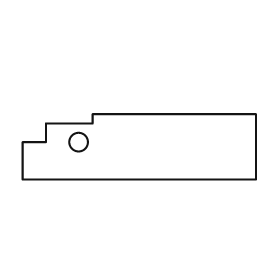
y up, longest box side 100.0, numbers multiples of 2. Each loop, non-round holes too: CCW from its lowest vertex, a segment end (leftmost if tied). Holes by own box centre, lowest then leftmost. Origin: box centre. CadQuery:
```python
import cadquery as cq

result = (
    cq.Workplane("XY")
    .moveTo(-50.0, -14.0)
    .lineTo(50.0, -14.0)
    .lineTo(50.0, 14.0)
    .lineTo(-20.0, 14.0)
    .lineTo(-20.0, 10.0)
    .lineTo(-40.0, 10.0)
    .lineTo(-40.0, 2.0)
    .lineTo(-50.0, 2.0)
    .close()
    .moveTo(-26.0, 2.0)
    .circle(4.0)
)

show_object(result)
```